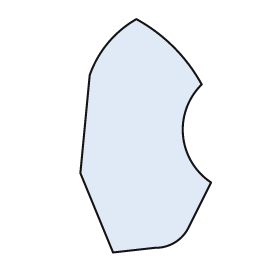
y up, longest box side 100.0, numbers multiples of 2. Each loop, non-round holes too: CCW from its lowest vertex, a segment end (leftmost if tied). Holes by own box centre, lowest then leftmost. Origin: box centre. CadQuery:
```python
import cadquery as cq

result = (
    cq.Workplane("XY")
    .moveTo(-14.0, -50.0)
    .lineTo(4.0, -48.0)
    .threePointArc((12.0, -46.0), (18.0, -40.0))
    .lineTo(28.0, -20.0)
    .threePointArc((16.0, 0.0), (24.0, 22.0))
    .threePointArc((12.0, 38.0), (-4.0, 50.0))
    .threePointArc((-16.0, 40.0), (-24.0, 26.0))
    .lineTo(-28.0, -16.0)
    .close()
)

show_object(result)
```